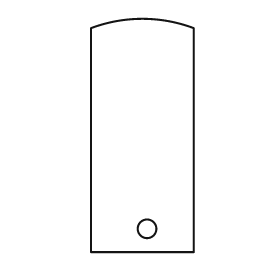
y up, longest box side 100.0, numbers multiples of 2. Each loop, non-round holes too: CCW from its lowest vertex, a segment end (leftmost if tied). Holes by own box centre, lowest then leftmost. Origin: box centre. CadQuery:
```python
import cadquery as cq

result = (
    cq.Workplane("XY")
    .moveTo(-22.0, -50.0)
    .lineTo(22.0, -50.0)
    .lineTo(22.0, 46.0)
    .threePointArc((0.0, 50.0), (-22.0, 46.0))
    .close()
    .moveTo(2.0, -40.0)
    .circle(4.0)
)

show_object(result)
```